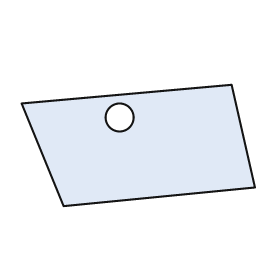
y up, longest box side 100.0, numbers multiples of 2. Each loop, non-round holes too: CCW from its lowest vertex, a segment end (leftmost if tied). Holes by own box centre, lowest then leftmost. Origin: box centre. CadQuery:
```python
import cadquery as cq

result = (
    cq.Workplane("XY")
    .moveTo(-32.0, -26.0)
    .lineTo(50.0, -18.0)
    .lineTo(40.0, 26.0)
    .lineTo(-50.0, 18.0)
    .close()
    .moveTo(-8.0, 12.0)
    .circle(6.0)
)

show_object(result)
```